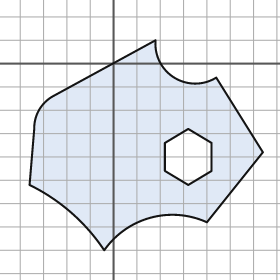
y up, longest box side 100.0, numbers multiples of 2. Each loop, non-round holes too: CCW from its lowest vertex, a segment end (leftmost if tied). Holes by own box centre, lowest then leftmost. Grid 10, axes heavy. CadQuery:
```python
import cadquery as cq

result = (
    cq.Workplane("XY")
    .moveTo(-4.0, -80.0)
    .threePointArc((16.0, -66.0), (40.0, -68.0))
    .lineTo(64.0, -38.0)
    .lineTo(44.0, -6.0)
    .threePointArc((26.0, -6.0), (18.0, 10.0))
    .lineTo(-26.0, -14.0)
    .threePointArc((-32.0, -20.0), (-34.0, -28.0))
    .lineTo(-36.0, -52.0)
    .threePointArc((-18.0, -64.0), (-4.0, -80.0))
    .close()
    .moveTo(32.0, -52.0)
    .lineTo(42.0, -46.0)
    .lineTo(42.0, -34.0)
    .lineTo(32.0, -28.0)
    .lineTo(22.0, -34.0)
    .lineTo(22.0, -46.0)
    .close()
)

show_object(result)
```